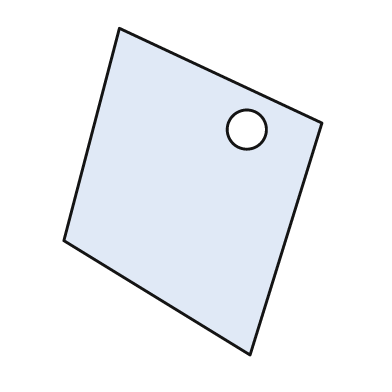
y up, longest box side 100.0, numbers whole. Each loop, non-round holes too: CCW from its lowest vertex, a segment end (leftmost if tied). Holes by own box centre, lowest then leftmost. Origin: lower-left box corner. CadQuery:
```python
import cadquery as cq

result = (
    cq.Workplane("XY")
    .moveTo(57.0, 0.0)
    .lineTo(79.0, 71.0)
    .lineTo(17.0, 100.0)
    .lineTo(0.0, 35.0)
    .close()
    .moveTo(56.0, 69.0)
    .circle(6.0)
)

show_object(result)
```